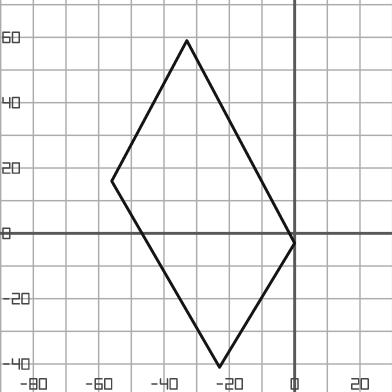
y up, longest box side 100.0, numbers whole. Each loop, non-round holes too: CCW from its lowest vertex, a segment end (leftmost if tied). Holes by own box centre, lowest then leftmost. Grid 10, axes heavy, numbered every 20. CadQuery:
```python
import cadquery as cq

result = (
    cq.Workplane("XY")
    .moveTo(-23.0, -41.0)
    .lineTo(0.0, -3.0)
    .lineTo(-33.0, 59.0)
    .lineTo(-56.0, 16.0)
    .close()
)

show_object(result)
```